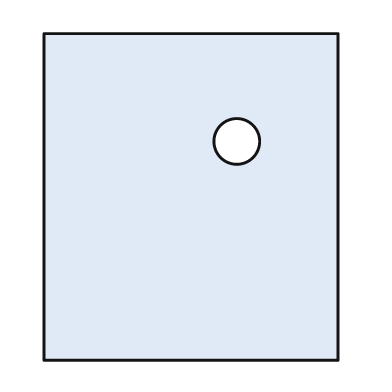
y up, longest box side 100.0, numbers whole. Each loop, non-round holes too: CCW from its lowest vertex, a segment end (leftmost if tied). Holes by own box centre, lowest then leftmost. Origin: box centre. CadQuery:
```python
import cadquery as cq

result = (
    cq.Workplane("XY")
    .moveTo(-45.0, -50.0)
    .lineTo(45.0, -50.0)
    .lineTo(45.0, 50.0)
    .lineTo(-45.0, 50.0)
    .close()
    .moveTo(14.0, 17.0)
    .circle(7.0)
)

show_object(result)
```